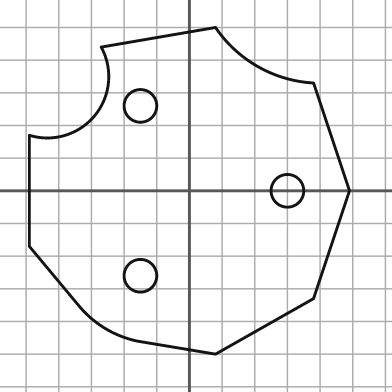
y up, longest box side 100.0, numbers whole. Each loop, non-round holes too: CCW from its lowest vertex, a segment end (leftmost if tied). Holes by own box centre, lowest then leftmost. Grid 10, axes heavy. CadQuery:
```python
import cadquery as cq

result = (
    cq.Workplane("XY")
    .moveTo(8.0, -50.0)
    .lineTo(38.0, -33.0)
    .lineTo(49.0, 0.0)
    .lineTo(38.0, 33.0)
    .threePointArc((21.0, 38.0), (8.0, 50.0))
    .lineTo(-27.0, 44.0)
    .threePointArc((-29.0, 23.0), (-49.0, 17.0))
    .lineTo(-49.0, -17.0)
    .lineTo(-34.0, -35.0)
    .threePointArc((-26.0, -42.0), (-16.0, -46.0))
    .close()
    .moveTo(-15.0, -26.0)
    .circle(5.0)
    .moveTo(30.0, 0.0)
    .circle(5.0)
    .moveTo(-15.0, 26.0)
    .circle(5.0)
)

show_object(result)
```